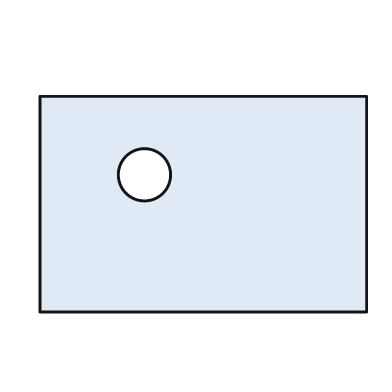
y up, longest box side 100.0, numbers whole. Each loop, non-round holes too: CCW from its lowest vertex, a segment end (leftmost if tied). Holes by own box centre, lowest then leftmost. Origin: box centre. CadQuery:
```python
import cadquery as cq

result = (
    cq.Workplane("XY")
    .moveTo(-50.0, -33.0)
    .lineTo(50.0, -33.0)
    .lineTo(50.0, 33.0)
    .lineTo(-50.0, 33.0)
    .close()
    .moveTo(-18.0, 9.0)
    .circle(8.0)
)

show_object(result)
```